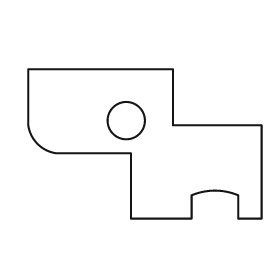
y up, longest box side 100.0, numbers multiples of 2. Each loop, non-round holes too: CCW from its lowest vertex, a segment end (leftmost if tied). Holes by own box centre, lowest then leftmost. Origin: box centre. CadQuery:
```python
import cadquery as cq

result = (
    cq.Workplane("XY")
    .moveTo(-6.0, -32.0)
    .lineTo(20.0, -32.0)
    .lineTo(20.0, -22.0)
    .threePointArc((30.0, -20.0), (40.0, -22.0))
    .lineTo(40.0, -32.0)
    .lineTo(50.0, -32.0)
    .lineTo(50.0, 8.0)
    .lineTo(12.0, 8.0)
    .lineTo(12.0, 32.0)
    .lineTo(-50.0, 32.0)
    .lineTo(-50.0, 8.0)
    .threePointArc((-46.0, 0.0), (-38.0, -4.0))
    .lineTo(-6.0, -4.0)
    .close()
    .moveTo(-8.0, 10.0)
    .circle(8.0)
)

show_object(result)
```